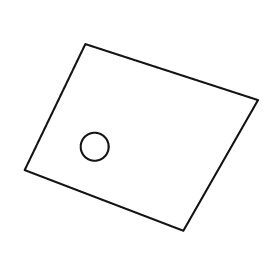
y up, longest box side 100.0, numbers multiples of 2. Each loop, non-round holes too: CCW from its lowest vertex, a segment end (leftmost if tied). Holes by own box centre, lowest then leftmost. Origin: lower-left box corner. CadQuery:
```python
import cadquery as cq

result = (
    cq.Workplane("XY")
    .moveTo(68.0, 0.0)
    .lineTo(100.0, 56.0)
    .lineTo(26.0, 80.0)
    .lineTo(0.0, 26.0)
    .close()
    .moveTo(30.0, 36.0)
    .circle(6.0)
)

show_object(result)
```